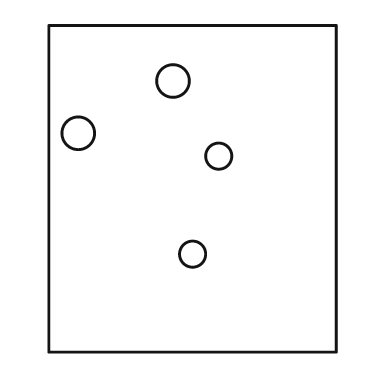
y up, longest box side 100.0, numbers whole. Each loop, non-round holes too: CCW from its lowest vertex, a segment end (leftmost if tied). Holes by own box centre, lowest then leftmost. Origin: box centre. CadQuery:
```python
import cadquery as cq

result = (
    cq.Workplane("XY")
    .moveTo(-44.0, -50.0)
    .lineTo(44.0, -50.0)
    .lineTo(44.0, 50.0)
    .lineTo(-44.0, 50.0)
    .close()
    .moveTo(0.0, -20.0)
    .circle(4.0)
    .moveTo(8.0, 10.0)
    .circle(4.0)
    .moveTo(-35.0, 17.0)
    .circle(5.0)
    .moveTo(-6.0, 33.0)
    .circle(5.0)
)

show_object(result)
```